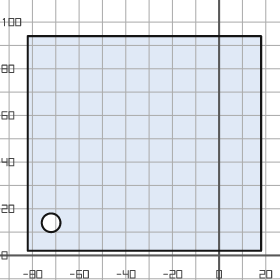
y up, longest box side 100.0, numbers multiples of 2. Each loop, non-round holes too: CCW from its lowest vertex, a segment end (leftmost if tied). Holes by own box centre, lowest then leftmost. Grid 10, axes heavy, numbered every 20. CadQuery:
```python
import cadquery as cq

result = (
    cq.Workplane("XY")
    .moveTo(-82.0, 2.0)
    .lineTo(18.0, 2.0)
    .lineTo(18.0, 94.0)
    .lineTo(-82.0, 94.0)
    .close()
    .moveTo(-72.0, 14.0)
    .circle(4.0)
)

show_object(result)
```